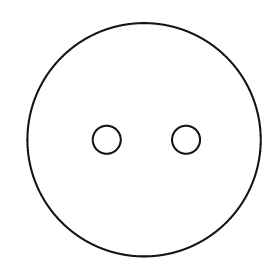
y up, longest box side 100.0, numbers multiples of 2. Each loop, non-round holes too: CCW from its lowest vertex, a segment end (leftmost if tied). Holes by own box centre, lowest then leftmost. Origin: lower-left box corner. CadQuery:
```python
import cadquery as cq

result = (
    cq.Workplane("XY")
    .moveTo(50.0, 50.0)
    .circle(50.0)
    .moveTo(34.0, 50.0)
    .circle(6.0)
    .moveTo(68.0, 50.0)
    .circle(6.0)
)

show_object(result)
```